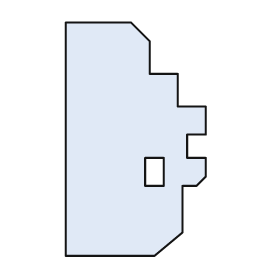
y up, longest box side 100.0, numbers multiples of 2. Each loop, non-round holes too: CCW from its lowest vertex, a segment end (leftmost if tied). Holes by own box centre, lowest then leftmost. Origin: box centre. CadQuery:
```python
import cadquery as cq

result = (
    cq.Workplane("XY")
    .moveTo(-30.0, -50.0)
    .lineTo(8.0, -50.0)
    .lineTo(20.0, -40.0)
    .lineTo(20.0, -20.0)
    .lineTo(26.0, -20.0)
    .lineTo(30.0, -16.0)
    .lineTo(30.0, -8.0)
    .lineTo(22.0, -8.0)
    .lineTo(22.0, 2.0)
    .lineTo(30.0, 2.0)
    .lineTo(30.0, 14.0)
    .lineTo(18.0, 14.0)
    .lineTo(18.0, 28.0)
    .lineTo(6.0, 28.0)
    .lineTo(6.0, 42.0)
    .lineTo(-2.0, 50.0)
    .lineTo(-30.0, 50.0)
    .close()
    .moveTo(4.0, -20.0)
    .lineTo(12.0, -20.0)
    .lineTo(12.0, -8.0)
    .lineTo(4.0, -8.0)
    .close()
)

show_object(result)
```